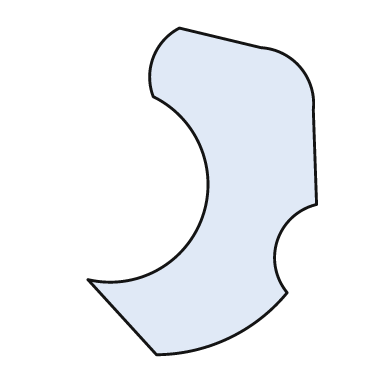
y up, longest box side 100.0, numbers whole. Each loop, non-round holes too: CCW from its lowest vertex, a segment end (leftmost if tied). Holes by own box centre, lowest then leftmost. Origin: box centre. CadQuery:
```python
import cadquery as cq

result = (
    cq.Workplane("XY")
    .moveTo(-14.0, -50.0)
    .threePointArc((8.0, -45.0), (26.0, -31.0))
    .threePointArc((23.0, -15.0), (35.0, -4.0))
    .lineTo(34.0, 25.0)
    .threePointArc((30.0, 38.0), (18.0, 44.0))
    .lineTo(-7.0, 50.0)
    .threePointArc((-15.0, 41.0), (-15.0, 29.0))
    .threePointArc((0.0, -8.0), (-35.0, -27.0))
    .close()
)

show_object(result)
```